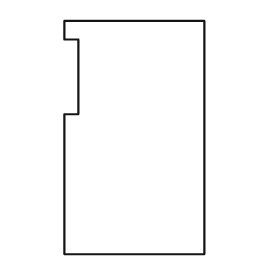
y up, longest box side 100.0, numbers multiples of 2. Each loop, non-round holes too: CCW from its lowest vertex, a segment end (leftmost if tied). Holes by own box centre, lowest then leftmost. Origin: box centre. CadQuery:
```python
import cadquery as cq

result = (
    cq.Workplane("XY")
    .moveTo(-30.0, -50.0)
    .lineTo(30.0, -50.0)
    .lineTo(30.0, 50.0)
    .lineTo(-30.0, 50.0)
    .lineTo(-30.0, 42.0)
    .lineTo(-24.0, 42.0)
    .lineTo(-24.0, 10.0)
    .lineTo(-30.0, 10.0)
    .close()
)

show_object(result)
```